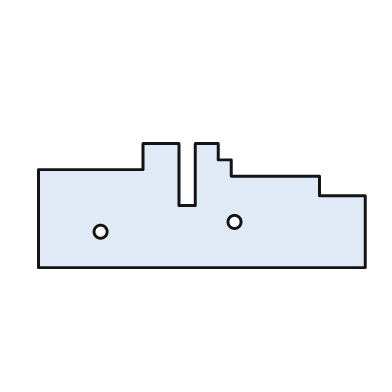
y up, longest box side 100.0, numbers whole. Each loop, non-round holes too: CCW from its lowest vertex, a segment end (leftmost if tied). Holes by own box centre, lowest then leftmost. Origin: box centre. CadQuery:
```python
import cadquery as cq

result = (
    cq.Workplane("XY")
    .moveTo(-50.0, -19.0)
    .lineTo(50.0, -19.0)
    .lineTo(50.0, 3.0)
    .lineTo(36.0, 3.0)
    .lineTo(36.0, 9.0)
    .lineTo(9.0, 9.0)
    .lineTo(9.0, 14.0)
    .lineTo(5.0, 14.0)
    .lineTo(5.0, 19.0)
    .lineTo(-2.0, 19.0)
    .lineTo(-2.0, 0.0)
    .lineTo(-7.0, 0.0)
    .lineTo(-7.0, 19.0)
    .lineTo(-18.0, 19.0)
    .lineTo(-18.0, 11.0)
    .lineTo(-50.0, 11.0)
    .close()
    .moveTo(-31.0, -8.0)
    .circle(2.0)
    .moveTo(10.0, -5.0)
    .circle(2.0)
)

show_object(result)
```